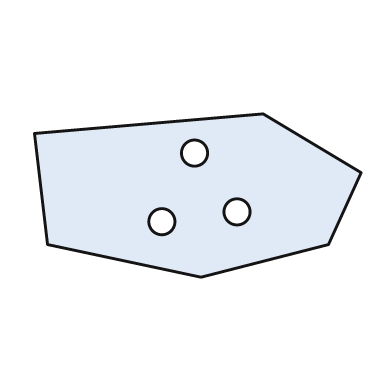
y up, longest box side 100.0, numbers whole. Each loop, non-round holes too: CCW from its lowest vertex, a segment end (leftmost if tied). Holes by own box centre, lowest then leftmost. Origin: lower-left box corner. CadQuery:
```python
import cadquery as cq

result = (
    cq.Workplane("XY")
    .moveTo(51.0, 0.0)
    .lineTo(90.0, 10.0)
    .lineTo(100.0, 32.0)
    .lineTo(70.0, 50.0)
    .lineTo(0.0, 44.0)
    .lineTo(4.0, 10.0)
    .close()
    .moveTo(39.0, 17.0)
    .circle(4.0)
    .moveTo(62.0, 20.0)
    .circle(4.0)
    .moveTo(49.0, 38.0)
    .circle(4.0)
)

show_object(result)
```